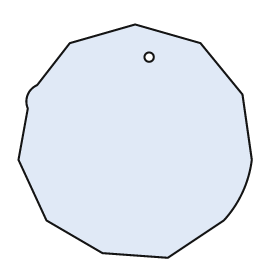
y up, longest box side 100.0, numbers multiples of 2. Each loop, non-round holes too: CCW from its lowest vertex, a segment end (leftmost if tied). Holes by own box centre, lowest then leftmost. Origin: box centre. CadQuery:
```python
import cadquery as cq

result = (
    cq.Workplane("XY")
    .moveTo(14.0, -50.0)
    .lineTo(38.0, -34.0)
    .threePointArc((46.0, -22.0), (50.0, -8.0))
    .lineTo(46.0, 20.0)
    .lineTo(28.0, 42.0)
    .lineTo(0.0, 50.0)
    .lineTo(-28.0, 42.0)
    .lineTo(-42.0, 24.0)
    .threePointArc((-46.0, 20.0), (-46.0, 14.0))
    .lineTo(-50.0, -8.0)
    .lineTo(-38.0, -34.0)
    .lineTo(-14.0, -48.0)
    .close()
    .moveTo(6.0, 36.0)
    .circle(2.0)
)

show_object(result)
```